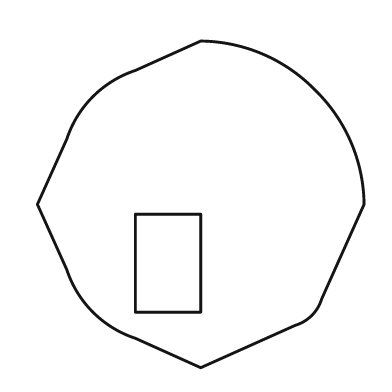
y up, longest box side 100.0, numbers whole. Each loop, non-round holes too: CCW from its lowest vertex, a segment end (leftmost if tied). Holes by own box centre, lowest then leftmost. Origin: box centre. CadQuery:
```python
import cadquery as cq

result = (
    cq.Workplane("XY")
    .moveTo(0.0, -50.0)
    .lineTo(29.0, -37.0)
    .threePointArc((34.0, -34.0), (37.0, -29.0))
    .lineTo(50.0, 0.0)
    .threePointArc((46.0, 19.0), (35.0, 35.0))
    .threePointArc((19.0, 46.0), (0.0, 50.0))
    .lineTo(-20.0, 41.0)
    .threePointArc((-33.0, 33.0), (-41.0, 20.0))
    .lineTo(-50.0, 0.0)
    .lineTo(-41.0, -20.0)
    .threePointArc((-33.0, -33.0), (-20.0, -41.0))
    .close()
    .moveTo(-20.0, -33.0)
    .lineTo(0.0, -33.0)
    .lineTo(0.0, -3.0)
    .lineTo(-20.0, -3.0)
    .close()
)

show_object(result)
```